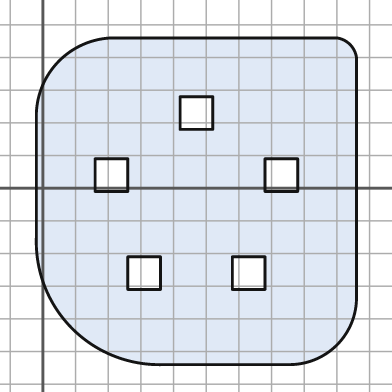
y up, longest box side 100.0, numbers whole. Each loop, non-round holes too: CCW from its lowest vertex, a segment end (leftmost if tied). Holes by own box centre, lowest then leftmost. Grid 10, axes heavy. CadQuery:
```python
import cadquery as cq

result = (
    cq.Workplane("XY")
    .moveTo(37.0, -54.0)
    .lineTo(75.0, -54.0)
    .threePointArc((90.0, -48.0), (96.0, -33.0))
    .lineTo(96.0, 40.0)
    .threePointArc((94.0, 44.0), (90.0, 46.0))
    .lineTo(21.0, 46.0)
    .threePointArc((5.0, 39.0), (-2.0, 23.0))
    .lineTo(-2.0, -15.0)
    .threePointArc((9.0, -43.0), (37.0, -54.0))
    .close()
    .moveTo(26.0, -31.0)
    .lineTo(36.0, -31.0)
    .lineTo(36.0, -21.0)
    .lineTo(26.0, -21.0)
    .close()
    .moveTo(58.0, -31.0)
    .lineTo(68.0, -31.0)
    .lineTo(68.0, -21.0)
    .lineTo(58.0, -21.0)
    .close()
    .moveTo(16.0, -1.0)
    .lineTo(26.0, -1.0)
    .lineTo(26.0, 9.0)
    .lineTo(16.0, 9.0)
    .close()
    .moveTo(68.0, -1.0)
    .lineTo(78.0, -1.0)
    .lineTo(78.0, 9.0)
    .lineTo(68.0, 9.0)
    .close()
    .moveTo(42.0, 18.0)
    .lineTo(52.0, 18.0)
    .lineTo(52.0, 28.0)
    .lineTo(42.0, 28.0)
    .close()
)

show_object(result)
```